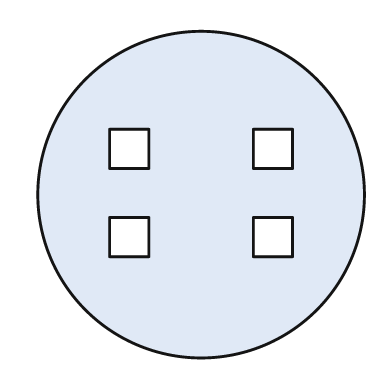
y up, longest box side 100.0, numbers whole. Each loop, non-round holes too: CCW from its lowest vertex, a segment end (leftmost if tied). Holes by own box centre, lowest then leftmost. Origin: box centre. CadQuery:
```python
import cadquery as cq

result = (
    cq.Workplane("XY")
    .moveTo(0.0, 0.0)
    .circle(50.0)
    .moveTo(-28.0, -19.0)
    .lineTo(-16.0, -19.0)
    .lineTo(-16.0, -7.0)
    .lineTo(-28.0, -7.0)
    .close()
    .moveTo(16.0, -19.0)
    .lineTo(28.0, -19.0)
    .lineTo(28.0, -7.0)
    .lineTo(16.0, -7.0)
    .close()
    .moveTo(-28.0, 8.0)
    .lineTo(-16.0, 8.0)
    .lineTo(-16.0, 20.0)
    .lineTo(-28.0, 20.0)
    .close()
    .moveTo(16.0, 8.0)
    .lineTo(28.0, 8.0)
    .lineTo(28.0, 20.0)
    .lineTo(16.0, 20.0)
    .close()
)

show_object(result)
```